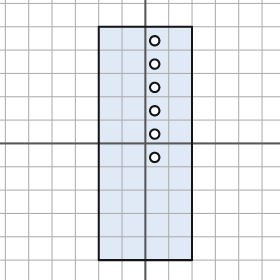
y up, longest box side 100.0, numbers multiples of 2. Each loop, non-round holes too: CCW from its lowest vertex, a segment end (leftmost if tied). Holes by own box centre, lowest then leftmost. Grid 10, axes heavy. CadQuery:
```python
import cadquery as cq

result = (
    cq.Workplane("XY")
    .moveTo(-20.0, -50.0)
    .lineTo(20.0, -50.0)
    .lineTo(20.0, 50.0)
    .lineTo(-20.0, 50.0)
    .close()
    .moveTo(4.0, -6.0)
    .circle(2.0)
    .moveTo(4.0, 4.0)
    .circle(2.0)
    .moveTo(4.0, 14.0)
    .circle(2.0)
    .moveTo(4.0, 24.0)
    .circle(2.0)
    .moveTo(4.0, 34.0)
    .circle(2.0)
    .moveTo(4.0, 44.0)
    .circle(2.0)
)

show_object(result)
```